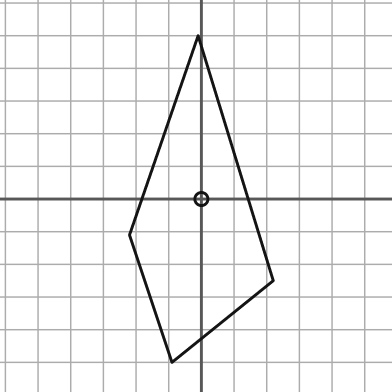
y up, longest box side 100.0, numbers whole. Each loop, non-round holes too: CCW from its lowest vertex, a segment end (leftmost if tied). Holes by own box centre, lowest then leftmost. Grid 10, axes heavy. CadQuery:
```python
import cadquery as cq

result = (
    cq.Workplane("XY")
    .moveTo(-9.0, -50.0)
    .lineTo(22.0, -25.0)
    .lineTo(-1.0, 50.0)
    .lineTo(-22.0, -11.0)
    .close()
    .moveTo(0.0, 0.0)
    .circle(2.0)
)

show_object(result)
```